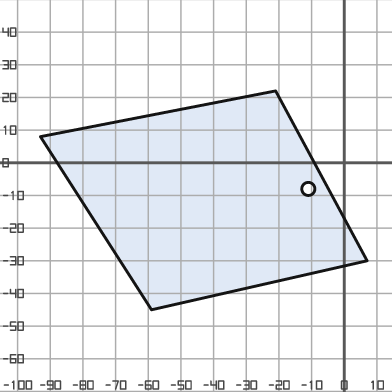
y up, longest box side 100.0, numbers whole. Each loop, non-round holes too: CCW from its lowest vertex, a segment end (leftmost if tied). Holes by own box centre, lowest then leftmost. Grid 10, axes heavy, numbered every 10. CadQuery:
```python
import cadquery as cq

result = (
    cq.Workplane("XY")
    .moveTo(-59.0, -45.0)
    .lineTo(7.0, -30.0)
    .lineTo(-21.0, 22.0)
    .lineTo(-93.0, 8.0)
    .close()
    .moveTo(-11.0, -8.0)
    .circle(2.0)
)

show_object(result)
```